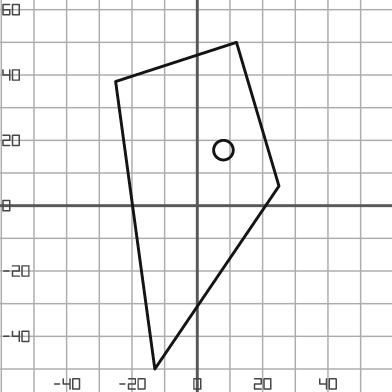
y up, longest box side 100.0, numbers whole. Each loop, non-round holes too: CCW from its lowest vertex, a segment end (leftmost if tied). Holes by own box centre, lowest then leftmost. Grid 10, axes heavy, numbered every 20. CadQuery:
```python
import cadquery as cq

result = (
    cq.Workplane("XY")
    .moveTo(-13.0, -50.0)
    .lineTo(25.0, 6.0)
    .lineTo(12.0, 50.0)
    .lineTo(-25.0, 38.0)
    .close()
    .moveTo(8.0, 17.0)
    .circle(3.0)
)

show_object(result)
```